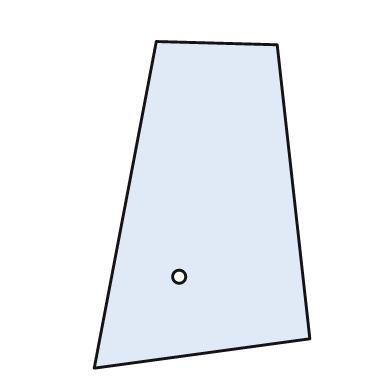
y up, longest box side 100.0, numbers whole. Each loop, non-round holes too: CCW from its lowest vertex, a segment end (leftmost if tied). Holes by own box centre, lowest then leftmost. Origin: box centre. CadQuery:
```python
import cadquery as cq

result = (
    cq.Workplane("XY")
    .moveTo(-33.0, -50.0)
    .lineTo(33.0, -41.0)
    .lineTo(23.0, 49.0)
    .lineTo(-14.0, 50.0)
    .close()
    .moveTo(-7.0, -22.0)
    .circle(2.0)
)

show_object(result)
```